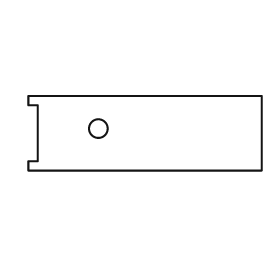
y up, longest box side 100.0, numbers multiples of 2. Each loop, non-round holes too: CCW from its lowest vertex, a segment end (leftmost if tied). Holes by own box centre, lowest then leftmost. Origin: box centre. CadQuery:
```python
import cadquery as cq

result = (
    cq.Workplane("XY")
    .moveTo(-50.0, -16.0)
    .lineTo(50.0, -16.0)
    .lineTo(50.0, 16.0)
    .lineTo(-50.0, 16.0)
    .lineTo(-50.0, 12.0)
    .lineTo(-46.0, 12.0)
    .lineTo(-46.0, -12.0)
    .lineTo(-50.0, -12.0)
    .close()
    .moveTo(-20.0, 2.0)
    .circle(4.0)
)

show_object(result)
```